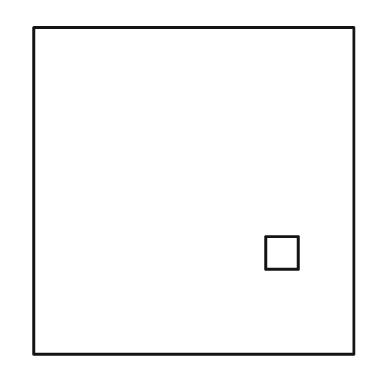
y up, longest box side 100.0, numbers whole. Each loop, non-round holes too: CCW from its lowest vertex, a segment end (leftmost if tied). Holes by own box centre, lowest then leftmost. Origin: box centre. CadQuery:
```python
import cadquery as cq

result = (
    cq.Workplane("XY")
    .moveTo(-49.0, -50.0)
    .lineTo(49.0, -50.0)
    .lineTo(49.0, 50.0)
    .lineTo(-49.0, 50.0)
    .close()
    .moveTo(22.0, -24.0)
    .lineTo(32.0, -24.0)
    .lineTo(32.0, -14.0)
    .lineTo(22.0, -14.0)
    .close()
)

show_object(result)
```